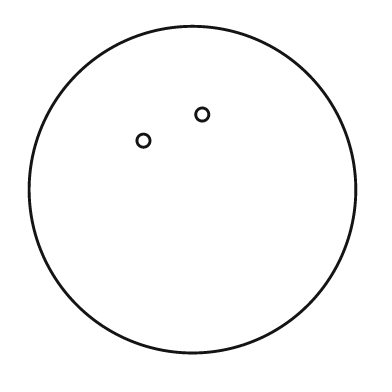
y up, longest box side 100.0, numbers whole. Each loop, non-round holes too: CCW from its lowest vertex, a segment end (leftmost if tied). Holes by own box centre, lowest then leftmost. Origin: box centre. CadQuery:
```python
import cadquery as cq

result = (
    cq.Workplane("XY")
    .moveTo(0.0, 0.0)
    .circle(50.0)
    .moveTo(-15.0, 15.0)
    .circle(2.0)
    .moveTo(3.0, 23.0)
    .circle(2.0)
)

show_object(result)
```